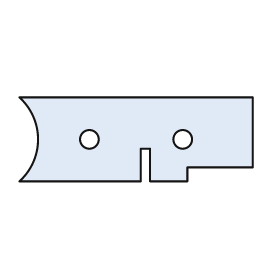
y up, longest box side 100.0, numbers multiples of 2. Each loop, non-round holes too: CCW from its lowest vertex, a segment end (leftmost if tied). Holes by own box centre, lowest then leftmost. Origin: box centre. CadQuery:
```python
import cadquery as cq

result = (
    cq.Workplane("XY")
    .moveTo(-50.0, -18.0)
    .lineTo(2.0, -18.0)
    .lineTo(2.0, -4.0)
    .lineTo(6.0, -4.0)
    .lineTo(6.0, -18.0)
    .lineTo(22.0, -18.0)
    .lineTo(22.0, -12.0)
    .lineTo(50.0, -12.0)
    .lineTo(50.0, 18.0)
    .lineTo(-50.0, 18.0)
    .threePointArc((-42.0, 0.0), (-50.0, -18.0))
    .close()
    .moveTo(-20.0, 0.0)
    .circle(4.0)
    .moveTo(20.0, 0.0)
    .circle(4.0)
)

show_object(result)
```